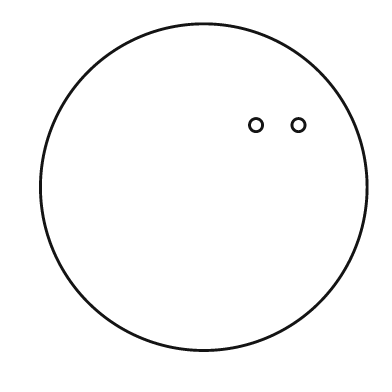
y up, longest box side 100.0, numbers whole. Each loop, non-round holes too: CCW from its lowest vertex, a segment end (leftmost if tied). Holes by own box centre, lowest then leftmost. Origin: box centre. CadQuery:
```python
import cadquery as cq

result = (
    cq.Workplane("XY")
    .moveTo(0.0, 0.0)
    .circle(50.0)
    .moveTo(16.0, 19.0)
    .circle(2.0)
    .moveTo(29.0, 19.0)
    .circle(2.0)
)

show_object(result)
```